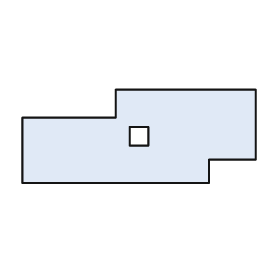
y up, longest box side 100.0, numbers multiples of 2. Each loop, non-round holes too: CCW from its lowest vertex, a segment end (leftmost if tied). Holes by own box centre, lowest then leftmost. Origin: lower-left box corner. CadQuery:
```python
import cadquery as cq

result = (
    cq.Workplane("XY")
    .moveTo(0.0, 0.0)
    .lineTo(80.0, 0.0)
    .lineTo(80.0, 10.0)
    .lineTo(100.0, 10.0)
    .lineTo(100.0, 40.0)
    .lineTo(40.0, 40.0)
    .lineTo(40.0, 28.0)
    .lineTo(0.0, 28.0)
    .close()
    .moveTo(46.0, 16.0)
    .lineTo(54.0, 16.0)
    .lineTo(54.0, 24.0)
    .lineTo(46.0, 24.0)
    .close()
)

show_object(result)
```